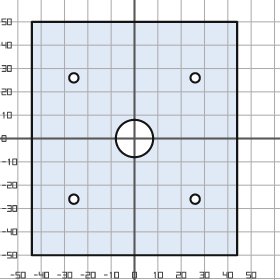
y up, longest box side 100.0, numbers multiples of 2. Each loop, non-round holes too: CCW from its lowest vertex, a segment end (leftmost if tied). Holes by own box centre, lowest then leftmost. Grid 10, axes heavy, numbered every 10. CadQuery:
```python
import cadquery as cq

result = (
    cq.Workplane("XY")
    .moveTo(-44.0, -50.0)
    .lineTo(44.0, -50.0)
    .lineTo(44.0, 50.0)
    .lineTo(-44.0, 50.0)
    .close()
    .moveTo(-26.0, -26.0)
    .circle(2.0)
    .moveTo(26.0, -26.0)
    .circle(2.0)
    .moveTo(0.0, 0.0)
    .circle(8.0)
    .moveTo(-26.0, 26.0)
    .circle(2.0)
    .moveTo(26.0, 26.0)
    .circle(2.0)
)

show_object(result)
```